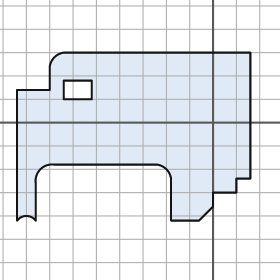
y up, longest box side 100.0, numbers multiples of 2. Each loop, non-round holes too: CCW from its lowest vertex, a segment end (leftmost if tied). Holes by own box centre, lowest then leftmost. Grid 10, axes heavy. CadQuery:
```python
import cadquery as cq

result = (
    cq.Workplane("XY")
    .moveTo(-84.0, -42.0)
    .threePointArc((-80.0, -40.0), (-76.0, -42.0))
    .lineTo(-76.0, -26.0)
    .threePointArc((-74.0, -20.0), (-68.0, -18.0))
    .lineTo(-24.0, -18.0)
    .threePointArc((-20.0, -20.0), (-18.0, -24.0))
    .lineTo(-18.0, -42.0)
    .lineTo(-6.0, -42.0)
    .lineTo(0.0, -36.0)
    .lineTo(0.0, -30.0)
    .lineTo(10.0, -30.0)
    .lineTo(10.0, -24.0)
    .lineTo(16.0, -24.0)
    .lineTo(16.0, 30.0)
    .lineTo(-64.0, 30.0)
    .threePointArc((-68.0, 28.0), (-70.0, 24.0))
    .lineTo(-70.0, 14.0)
    .lineTo(-84.0, 14.0)
    .close()
    .moveTo(-64.0, 10.0)
    .lineTo(-52.0, 10.0)
    .lineTo(-52.0, 18.0)
    .lineTo(-64.0, 18.0)
    .close()
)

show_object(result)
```